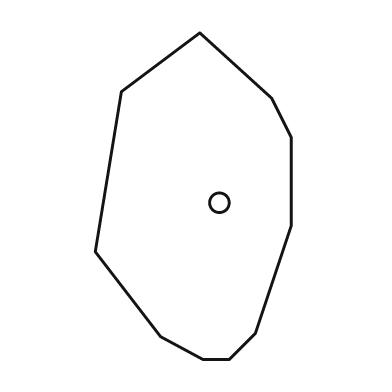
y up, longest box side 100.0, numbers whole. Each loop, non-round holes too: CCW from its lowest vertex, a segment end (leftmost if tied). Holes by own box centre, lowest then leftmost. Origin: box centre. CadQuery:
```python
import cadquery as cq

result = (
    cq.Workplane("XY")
    .moveTo(3.0, -50.0)
    .lineTo(11.0, -50.0)
    .lineTo(19.0, -42.0)
    .lineTo(30.0, -9.0)
    .lineTo(30.0, 18.0)
    .lineTo(24.0, 30.0)
    .lineTo(2.0, 50.0)
    .lineTo(-22.0, 32.0)
    .lineTo(-30.0, -17.0)
    .lineTo(-10.0, -43.0)
    .close()
    .moveTo(8.0, -2.0)
    .circle(3.0)
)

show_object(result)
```